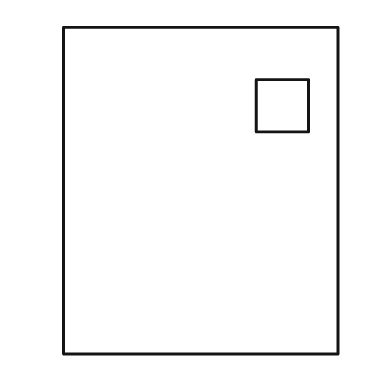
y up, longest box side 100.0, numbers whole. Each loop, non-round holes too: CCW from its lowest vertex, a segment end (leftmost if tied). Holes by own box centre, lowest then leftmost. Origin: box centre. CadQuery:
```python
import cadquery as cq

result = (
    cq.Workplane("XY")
    .moveTo(-42.0, -50.0)
    .lineTo(42.0, -50.0)
    .lineTo(42.0, 50.0)
    .lineTo(-42.0, 50.0)
    .close()
    .moveTo(17.0, 18.0)
    .lineTo(33.0, 18.0)
    .lineTo(33.0, 34.0)
    .lineTo(17.0, 34.0)
    .close()
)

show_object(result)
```